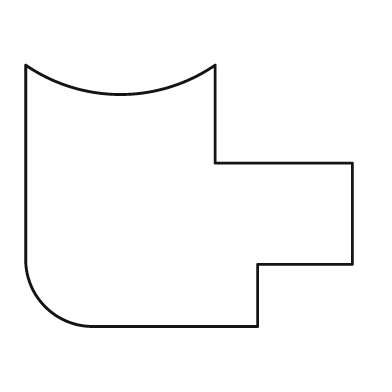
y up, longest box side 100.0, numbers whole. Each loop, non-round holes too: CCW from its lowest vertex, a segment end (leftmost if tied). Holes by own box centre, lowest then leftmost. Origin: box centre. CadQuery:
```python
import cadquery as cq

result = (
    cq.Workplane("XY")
    .moveTo(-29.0, -40.0)
    .lineTo(21.0, -40.0)
    .lineTo(21.0, -21.0)
    .lineTo(50.0, -21.0)
    .lineTo(50.0, 10.0)
    .lineTo(8.0, 10.0)
    .lineTo(8.0, 40.0)
    .threePointArc((-21.0, 31.0), (-50.0, 40.0))
    .lineTo(-50.0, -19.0)
    .threePointArc((-44.0, -34.0), (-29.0, -40.0))
    .close()
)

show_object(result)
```